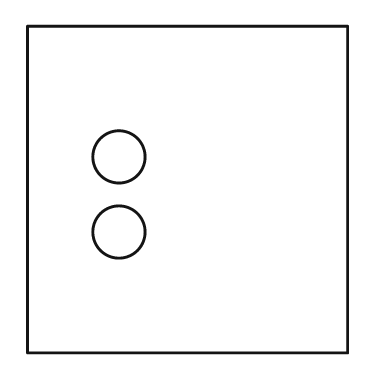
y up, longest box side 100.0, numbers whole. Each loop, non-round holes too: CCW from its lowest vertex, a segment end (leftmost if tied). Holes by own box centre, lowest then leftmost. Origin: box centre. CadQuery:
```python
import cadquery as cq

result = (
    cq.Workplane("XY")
    .moveTo(-49.0, -50.0)
    .lineTo(49.0, -50.0)
    .lineTo(49.0, 50.0)
    .lineTo(-49.0, 50.0)
    .close()
    .moveTo(-21.0, -13.0)
    .circle(8.0)
    .moveTo(-21.0, 10.0)
    .circle(8.0)
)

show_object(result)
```